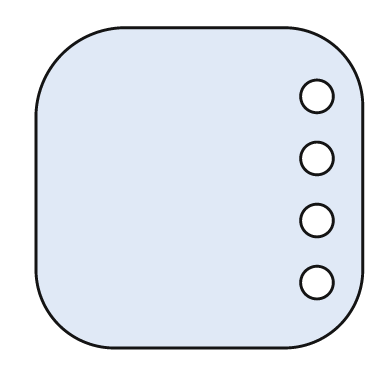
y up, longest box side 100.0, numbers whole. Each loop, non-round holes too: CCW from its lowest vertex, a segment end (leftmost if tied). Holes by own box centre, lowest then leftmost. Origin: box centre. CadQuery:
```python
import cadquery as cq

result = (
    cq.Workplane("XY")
    .moveTo(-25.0, -49.0)
    .lineTo(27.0, -49.0)
    .threePointArc((43.0, -42.0), (50.0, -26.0))
    .lineTo(50.0, 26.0)
    .threePointArc((43.0, 42.0), (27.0, 49.0))
    .lineTo(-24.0, 49.0)
    .threePointArc((-42.0, 41.0), (-50.0, 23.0))
    .lineTo(-50.0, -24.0)
    .threePointArc((-43.0, -42.0), (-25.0, -49.0))
    .close()
    .moveTo(36.0, -29.0)
    .circle(5.0)
    .moveTo(36.0, -10.0)
    .circle(5.0)
    .moveTo(36.0, 9.0)
    .circle(5.0)
    .moveTo(36.0, 28.0)
    .circle(5.0)
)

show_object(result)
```